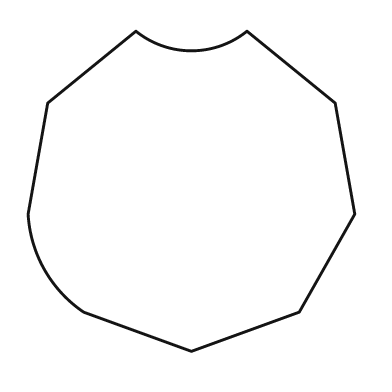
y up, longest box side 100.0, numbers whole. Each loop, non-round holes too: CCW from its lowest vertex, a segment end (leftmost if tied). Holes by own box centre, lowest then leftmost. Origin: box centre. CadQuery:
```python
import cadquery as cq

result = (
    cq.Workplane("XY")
    .moveTo(0.0, -49.0)
    .lineTo(33.0, -37.0)
    .lineTo(50.0, -7.0)
    .lineTo(44.0, 27.0)
    .lineTo(17.0, 49.0)
    .threePointArc((0.0, 43.0), (-17.0, 49.0))
    .lineTo(-44.0, 27.0)
    .lineTo(-50.0, -7.0)
    .threePointArc((-45.0, -24.0), (-33.0, -37.0))
    .close()
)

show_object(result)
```